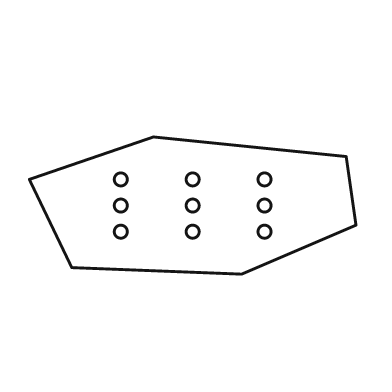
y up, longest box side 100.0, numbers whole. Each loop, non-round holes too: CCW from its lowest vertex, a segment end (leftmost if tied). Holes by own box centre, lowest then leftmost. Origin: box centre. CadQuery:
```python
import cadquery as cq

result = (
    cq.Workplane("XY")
    .moveTo(15.0, -21.0)
    .lineTo(50.0, -6.0)
    .lineTo(47.0, 15.0)
    .lineTo(-12.0, 21.0)
    .lineTo(-50.0, 8.0)
    .lineTo(-37.0, -19.0)
    .close()
    .moveTo(-22.0, -8.0)
    .circle(2.0)
    .moveTo(0.0, -8.0)
    .circle(2.0)
    .moveTo(22.0, -8.0)
    .circle(2.0)
    .moveTo(-22.0, 0.0)
    .circle(2.0)
    .moveTo(0.0, 0.0)
    .circle(2.0)
    .moveTo(22.0, 0.0)
    .circle(2.0)
    .moveTo(-22.0, 8.0)
    .circle(2.0)
    .moveTo(0.0, 8.0)
    .circle(2.0)
    .moveTo(22.0, 8.0)
    .circle(2.0)
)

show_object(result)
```